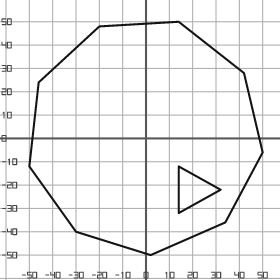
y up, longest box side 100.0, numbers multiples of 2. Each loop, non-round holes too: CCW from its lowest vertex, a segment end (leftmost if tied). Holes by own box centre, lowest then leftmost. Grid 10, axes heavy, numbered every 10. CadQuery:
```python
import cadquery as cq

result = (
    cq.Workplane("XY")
    .moveTo(2.0, -50.0)
    .lineTo(34.0, -36.0)
    .lineTo(50.0, -6.0)
    .lineTo(42.0, 28.0)
    .lineTo(14.0, 50.0)
    .lineTo(-20.0, 48.0)
    .lineTo(-46.0, 24.0)
    .lineTo(-50.0, -12.0)
    .lineTo(-30.0, -40.0)
    .close()
    .moveTo(14.0, -32.0)
    .lineTo(32.0, -22.0)
    .lineTo(14.0, -12.0)
    .close()
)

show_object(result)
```